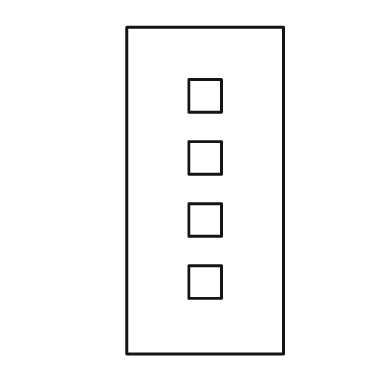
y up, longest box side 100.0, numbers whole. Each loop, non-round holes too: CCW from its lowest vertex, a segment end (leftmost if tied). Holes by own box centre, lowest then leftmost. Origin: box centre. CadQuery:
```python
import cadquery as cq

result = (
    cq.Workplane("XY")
    .moveTo(-24.0, -50.0)
    .lineTo(24.0, -50.0)
    .lineTo(24.0, 50.0)
    .lineTo(-24.0, 50.0)
    .close()
    .moveTo(-5.0, -33.0)
    .lineTo(5.0, -33.0)
    .lineTo(5.0, -23.0)
    .lineTo(-5.0, -23.0)
    .close()
    .moveTo(-5.0, -14.0)
    .lineTo(5.0, -14.0)
    .lineTo(5.0, -4.0)
    .lineTo(-5.0, -4.0)
    .close()
    .moveTo(-5.0, 5.0)
    .lineTo(5.0, 5.0)
    .lineTo(5.0, 15.0)
    .lineTo(-5.0, 15.0)
    .close()
    .moveTo(-5.0, 24.0)
    .lineTo(5.0, 24.0)
    .lineTo(5.0, 34.0)
    .lineTo(-5.0, 34.0)
    .close()
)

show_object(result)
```